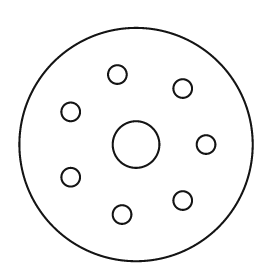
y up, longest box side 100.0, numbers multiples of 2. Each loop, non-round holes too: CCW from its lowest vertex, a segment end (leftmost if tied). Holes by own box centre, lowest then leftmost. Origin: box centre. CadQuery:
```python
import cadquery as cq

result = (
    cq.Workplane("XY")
    .moveTo(0.0, 0.0)
    .circle(50.0)
    .moveTo(-6.0, -30.0)
    .circle(4.0)
    .moveTo(20.0, -24.0)
    .circle(4.0)
    .moveTo(-28.0, -14.0)
    .circle(4.0)
    .moveTo(0.0, 0.0)
    .circle(10.0)
    .moveTo(30.0, 0.0)
    .circle(4.0)
    .moveTo(-28.0, 14.0)
    .circle(4.0)
    .moveTo(20.0, 24.0)
    .circle(4.0)
    .moveTo(-8.0, 30.0)
    .circle(4.0)
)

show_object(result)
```